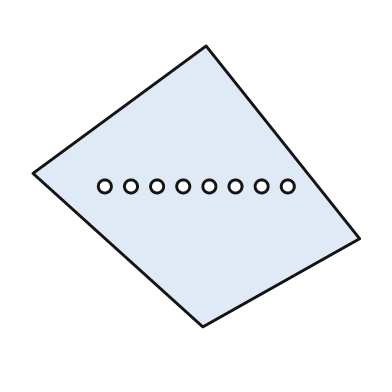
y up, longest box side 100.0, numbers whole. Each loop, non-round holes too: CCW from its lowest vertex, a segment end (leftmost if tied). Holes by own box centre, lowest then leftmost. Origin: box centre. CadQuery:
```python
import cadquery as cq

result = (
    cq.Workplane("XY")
    .moveTo(2.0, -43.0)
    .lineTo(50.0, -16.0)
    .lineTo(3.0, 43.0)
    .lineTo(-50.0, 4.0)
    .close()
    .moveTo(-28.0, 0.0)
    .circle(2.0)
    .moveTo(-20.0, 0.0)
    .circle(2.0)
    .moveTo(-12.0, 0.0)
    .circle(2.0)
    .moveTo(-4.0, 0.0)
    .circle(2.0)
    .moveTo(4.0, 0.0)
    .circle(2.0)
    .moveTo(12.0, 0.0)
    .circle(2.0)
    .moveTo(20.0, 0.0)
    .circle(2.0)
    .moveTo(28.0, 0.0)
    .circle(2.0)
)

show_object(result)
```